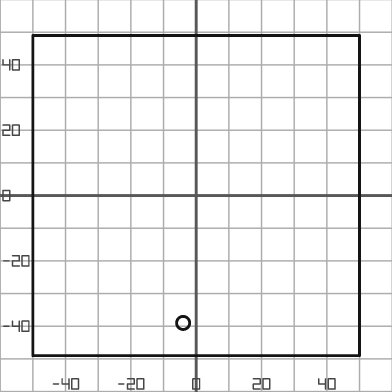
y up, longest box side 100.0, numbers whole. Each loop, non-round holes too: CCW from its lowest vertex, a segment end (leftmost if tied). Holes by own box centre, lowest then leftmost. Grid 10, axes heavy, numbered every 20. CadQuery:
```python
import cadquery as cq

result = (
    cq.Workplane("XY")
    .moveTo(-50.0, -49.0)
    .lineTo(50.0, -49.0)
    .lineTo(50.0, 49.0)
    .lineTo(-50.0, 49.0)
    .close()
    .moveTo(-4.0, -39.0)
    .circle(2.0)
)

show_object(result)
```